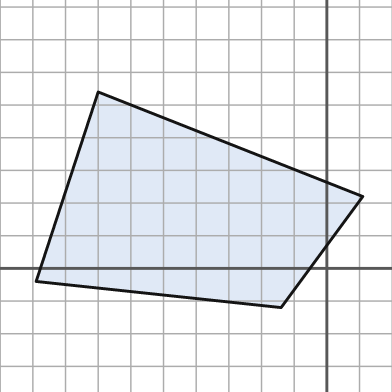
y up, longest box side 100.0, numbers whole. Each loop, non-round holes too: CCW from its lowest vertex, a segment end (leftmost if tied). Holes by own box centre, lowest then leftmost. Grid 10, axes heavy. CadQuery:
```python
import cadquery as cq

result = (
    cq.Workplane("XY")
    .moveTo(-14.0, -12.0)
    .lineTo(11.0, 22.0)
    .lineTo(-70.0, 54.0)
    .lineTo(-89.0, -4.0)
    .close()
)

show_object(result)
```